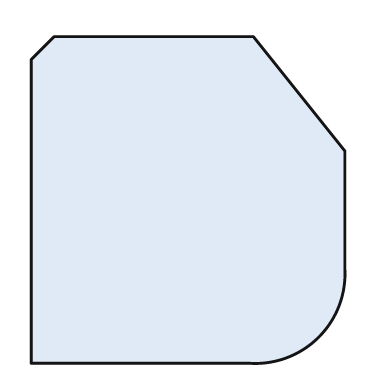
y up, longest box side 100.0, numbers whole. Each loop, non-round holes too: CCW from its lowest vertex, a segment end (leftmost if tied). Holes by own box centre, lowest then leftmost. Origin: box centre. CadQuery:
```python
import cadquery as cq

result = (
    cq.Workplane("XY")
    .moveTo(-48.0, -50.0)
    .lineTo(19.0, -50.0)
    .threePointArc((40.0, -42.0), (48.0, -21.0))
    .lineTo(48.0, 15.0)
    .lineTo(20.0, 50.0)
    .lineTo(-41.0, 50.0)
    .lineTo(-48.0, 43.0)
    .close()
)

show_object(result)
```